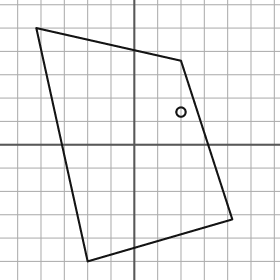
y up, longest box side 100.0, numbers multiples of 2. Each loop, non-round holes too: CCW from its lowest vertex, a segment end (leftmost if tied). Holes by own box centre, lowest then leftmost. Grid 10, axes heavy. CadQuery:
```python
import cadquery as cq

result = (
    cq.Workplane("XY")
    .moveTo(-20.0, -50.0)
    .lineTo(42.0, -32.0)
    .lineTo(20.0, 36.0)
    .lineTo(-42.0, 50.0)
    .close()
    .moveTo(20.0, 14.0)
    .circle(2.0)
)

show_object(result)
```